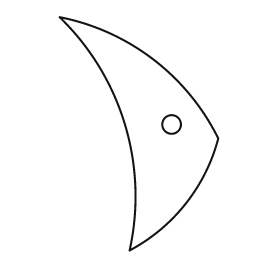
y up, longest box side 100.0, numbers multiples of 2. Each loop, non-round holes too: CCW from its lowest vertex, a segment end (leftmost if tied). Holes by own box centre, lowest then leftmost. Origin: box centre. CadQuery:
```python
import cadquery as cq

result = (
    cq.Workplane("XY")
    .moveTo(-4.0, -50.0)
    .threePointArc((20.0, -30.0), (34.0, -2.0))
    .threePointArc((6.0, 32.0), (-34.0, 50.0))
    .threePointArc((-6.0, 4.0), (-4.0, -50.0))
    .close()
    .moveTo(14.0, 4.0)
    .circle(4.0)
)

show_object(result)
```